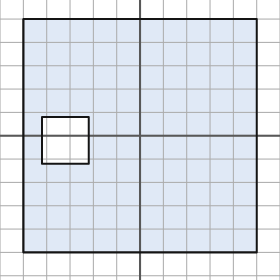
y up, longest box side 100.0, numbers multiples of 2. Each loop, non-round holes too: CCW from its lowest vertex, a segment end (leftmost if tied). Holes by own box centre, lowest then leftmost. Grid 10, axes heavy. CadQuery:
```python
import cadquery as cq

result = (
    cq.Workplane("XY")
    .moveTo(-50.0, -50.0)
    .lineTo(50.0, -50.0)
    .lineTo(50.0, 50.0)
    .lineTo(-50.0, 50.0)
    .close()
    .moveTo(-42.0, -12.0)
    .lineTo(-22.0, -12.0)
    .lineTo(-22.0, 8.0)
    .lineTo(-42.0, 8.0)
    .close()
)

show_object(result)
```